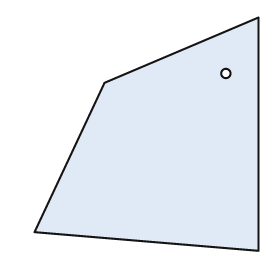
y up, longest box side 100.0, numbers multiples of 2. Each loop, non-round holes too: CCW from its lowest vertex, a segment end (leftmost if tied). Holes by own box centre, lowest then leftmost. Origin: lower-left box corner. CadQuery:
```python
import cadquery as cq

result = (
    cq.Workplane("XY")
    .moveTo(96.0, 0.0)
    .lineTo(96.0, 100.0)
    .lineTo(30.0, 72.0)
    .lineTo(0.0, 8.0)
    .close()
    .moveTo(82.0, 76.0)
    .circle(2.0)
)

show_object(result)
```